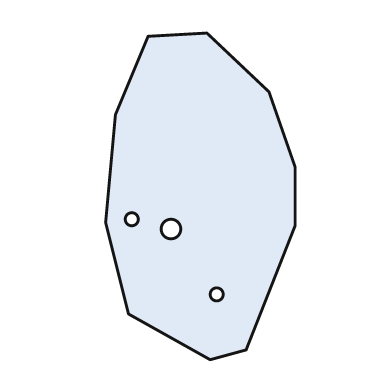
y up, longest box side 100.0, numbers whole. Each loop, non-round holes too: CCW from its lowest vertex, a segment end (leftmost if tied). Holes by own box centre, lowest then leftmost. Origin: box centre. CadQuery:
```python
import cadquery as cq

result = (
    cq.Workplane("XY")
    .moveTo(3.0, -50.0)
    .lineTo(14.0, -47.0)
    .lineTo(29.0, -9.0)
    .lineTo(29.0, 9.0)
    .lineTo(21.0, 32.0)
    .lineTo(2.0, 50.0)
    .lineTo(-16.0, 49.0)
    .lineTo(-26.0, 25.0)
    .lineTo(-29.0, -8.0)
    .lineTo(-22.0, -36.0)
    .close()
    .moveTo(5.0, -30.0)
    .circle(2.0)
    .moveTo(-9.0, -10.0)
    .circle(3.0)
    .moveTo(-21.0, -7.0)
    .circle(2.0)
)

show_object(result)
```